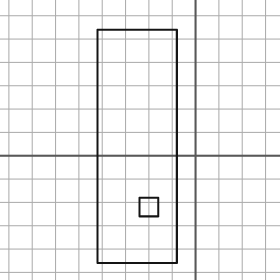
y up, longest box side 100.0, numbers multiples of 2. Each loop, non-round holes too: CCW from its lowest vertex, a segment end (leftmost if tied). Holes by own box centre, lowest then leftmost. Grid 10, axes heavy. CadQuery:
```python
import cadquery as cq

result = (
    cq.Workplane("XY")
    .moveTo(-42.0, -46.0)
    .lineTo(-8.0, -46.0)
    .lineTo(-8.0, 54.0)
    .lineTo(-42.0, 54.0)
    .close()
    .moveTo(-24.0, -26.0)
    .lineTo(-16.0, -26.0)
    .lineTo(-16.0, -18.0)
    .lineTo(-24.0, -18.0)
    .close()
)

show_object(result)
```